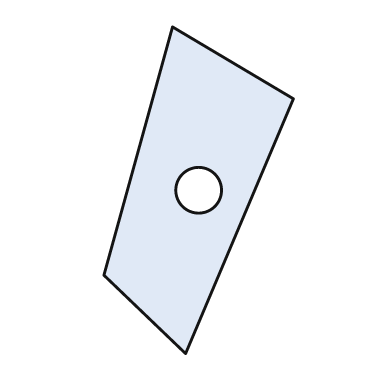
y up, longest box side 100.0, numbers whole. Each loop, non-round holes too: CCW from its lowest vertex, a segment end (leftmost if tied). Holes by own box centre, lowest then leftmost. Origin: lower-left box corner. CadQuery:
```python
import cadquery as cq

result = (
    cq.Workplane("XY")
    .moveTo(25.0, 0.0)
    .lineTo(58.0, 78.0)
    .lineTo(21.0, 100.0)
    .lineTo(0.0, 24.0)
    .close()
    .moveTo(29.0, 50.0)
    .circle(7.0)
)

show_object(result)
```